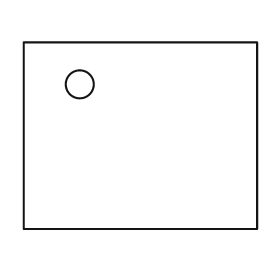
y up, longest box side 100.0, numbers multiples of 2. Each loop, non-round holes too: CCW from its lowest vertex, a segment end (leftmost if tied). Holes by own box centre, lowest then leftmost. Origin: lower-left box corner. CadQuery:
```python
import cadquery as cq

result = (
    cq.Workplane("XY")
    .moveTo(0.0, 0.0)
    .lineTo(100.0, 0.0)
    .lineTo(100.0, 80.0)
    .lineTo(0.0, 80.0)
    .close()
    .moveTo(24.0, 62.0)
    .circle(6.0)
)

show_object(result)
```